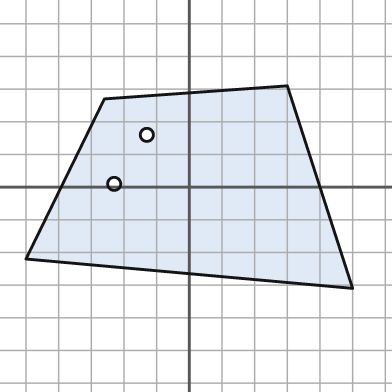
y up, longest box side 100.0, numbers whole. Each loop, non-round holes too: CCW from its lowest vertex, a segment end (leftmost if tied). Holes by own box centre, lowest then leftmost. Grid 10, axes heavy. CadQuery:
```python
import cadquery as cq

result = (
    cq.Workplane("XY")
    .moveTo(50.0, -31.0)
    .lineTo(30.0, 31.0)
    .lineTo(-26.0, 27.0)
    .lineTo(-50.0, -22.0)
    .close()
    .moveTo(-23.0, 1.0)
    .circle(2.0)
    .moveTo(-13.0, 16.0)
    .circle(2.0)
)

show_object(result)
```